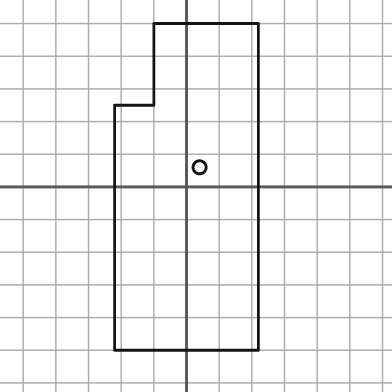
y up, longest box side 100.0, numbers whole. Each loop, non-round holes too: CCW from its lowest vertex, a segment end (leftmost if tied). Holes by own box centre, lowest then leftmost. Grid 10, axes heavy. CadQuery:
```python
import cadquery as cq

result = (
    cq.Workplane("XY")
    .moveTo(-22.0, -50.0)
    .lineTo(22.0, -50.0)
    .lineTo(22.0, 50.0)
    .lineTo(-10.0, 50.0)
    .lineTo(-10.0, 25.0)
    .lineTo(-22.0, 25.0)
    .close()
    .moveTo(4.0, 6.0)
    .circle(2.0)
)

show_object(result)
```